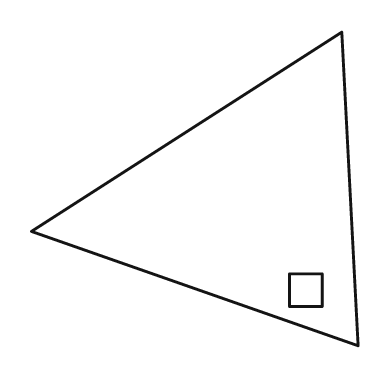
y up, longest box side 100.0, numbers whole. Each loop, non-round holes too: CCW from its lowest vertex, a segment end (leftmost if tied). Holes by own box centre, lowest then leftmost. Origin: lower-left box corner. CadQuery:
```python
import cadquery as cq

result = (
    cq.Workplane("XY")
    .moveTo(100.0, 0.0)
    .lineTo(95.0, 96.0)
    .lineTo(0.0, 35.0)
    .close()
    .moveTo(79.0, 12.0)
    .lineTo(89.0, 12.0)
    .lineTo(89.0, 22.0)
    .lineTo(79.0, 22.0)
    .close()
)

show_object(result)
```